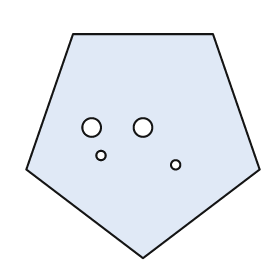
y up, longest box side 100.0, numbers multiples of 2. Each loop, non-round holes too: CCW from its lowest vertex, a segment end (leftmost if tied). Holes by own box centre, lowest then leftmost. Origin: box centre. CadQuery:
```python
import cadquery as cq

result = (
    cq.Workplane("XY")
    .moveTo(0.0, -48.0)
    .lineTo(50.0, -10.0)
    .lineTo(30.0, 48.0)
    .lineTo(-30.0, 48.0)
    .lineTo(-50.0, -10.0)
    .close()
    .moveTo(14.0, -8.0)
    .circle(2.0)
    .moveTo(-18.0, -4.0)
    .circle(2.0)
    .moveTo(-22.0, 8.0)
    .circle(4.0)
    .moveTo(0.0, 8.0)
    .circle(4.0)
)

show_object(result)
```